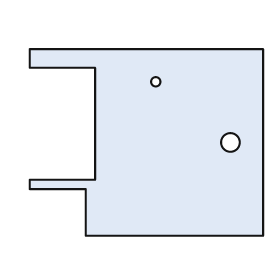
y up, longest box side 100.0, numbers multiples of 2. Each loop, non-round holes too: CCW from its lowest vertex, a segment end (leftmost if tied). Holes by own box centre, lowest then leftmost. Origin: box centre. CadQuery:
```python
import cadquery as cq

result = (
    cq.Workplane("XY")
    .moveTo(-26.0, -40.0)
    .lineTo(50.0, -40.0)
    .lineTo(50.0, 40.0)
    .lineTo(-50.0, 40.0)
    .lineTo(-50.0, 32.0)
    .lineTo(-22.0, 32.0)
    .lineTo(-22.0, -16.0)
    .lineTo(-50.0, -16.0)
    .lineTo(-50.0, -20.0)
    .lineTo(-26.0, -20.0)
    .close()
    .moveTo(36.0, 0.0)
    .circle(4.0)
    .moveTo(4.0, 26.0)
    .circle(2.0)
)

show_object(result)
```